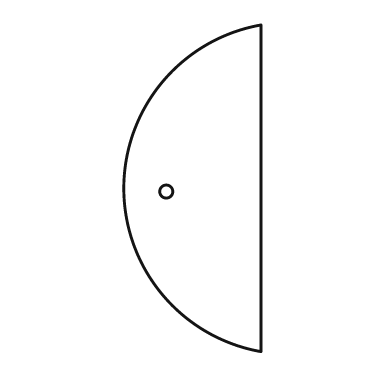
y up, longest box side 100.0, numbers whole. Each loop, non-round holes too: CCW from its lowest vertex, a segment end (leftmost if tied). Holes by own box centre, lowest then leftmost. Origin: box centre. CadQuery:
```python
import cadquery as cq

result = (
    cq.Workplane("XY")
    .moveTo(21.0, -50.0)
    .lineTo(21.0, 50.0)
    .threePointArc((-21.0, 0.0), (21.0, -50.0))
    .close()
    .moveTo(-8.0, -1.0)
    .circle(2.0)
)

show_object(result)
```